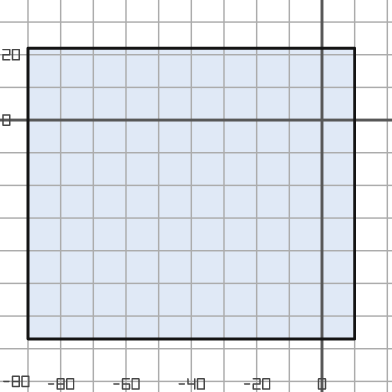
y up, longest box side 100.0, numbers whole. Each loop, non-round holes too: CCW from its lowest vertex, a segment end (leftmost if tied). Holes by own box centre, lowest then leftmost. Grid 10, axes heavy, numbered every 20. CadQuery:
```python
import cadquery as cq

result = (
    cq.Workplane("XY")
    .moveTo(-90.0, -67.0)
    .lineTo(10.0, -67.0)
    .lineTo(10.0, 22.0)
    .lineTo(-90.0, 22.0)
    .close()
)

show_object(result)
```